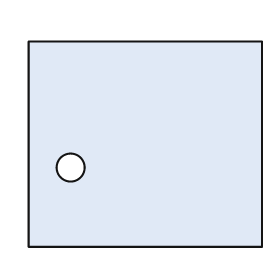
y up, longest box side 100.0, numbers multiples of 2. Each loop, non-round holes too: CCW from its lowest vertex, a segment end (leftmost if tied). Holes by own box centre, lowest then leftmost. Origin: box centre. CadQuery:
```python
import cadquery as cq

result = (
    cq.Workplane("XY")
    .moveTo(-50.0, -44.0)
    .lineTo(50.0, -44.0)
    .lineTo(50.0, 44.0)
    .lineTo(-50.0, 44.0)
    .close()
    .moveTo(-32.0, -10.0)
    .circle(6.0)
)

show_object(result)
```